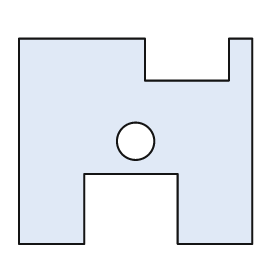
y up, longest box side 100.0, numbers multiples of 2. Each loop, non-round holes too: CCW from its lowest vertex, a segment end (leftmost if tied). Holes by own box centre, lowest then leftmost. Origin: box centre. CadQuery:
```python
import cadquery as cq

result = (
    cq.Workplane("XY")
    .moveTo(-50.0, -44.0)
    .lineTo(-22.0, -44.0)
    .lineTo(-22.0, -14.0)
    .lineTo(18.0, -14.0)
    .lineTo(18.0, -44.0)
    .lineTo(50.0, -44.0)
    .lineTo(50.0, 44.0)
    .lineTo(40.0, 44.0)
    .lineTo(40.0, 26.0)
    .lineTo(4.0, 26.0)
    .lineTo(4.0, 44.0)
    .lineTo(-50.0, 44.0)
    .close()
    .moveTo(0.0, 0.0)
    .circle(8.0)
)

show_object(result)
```